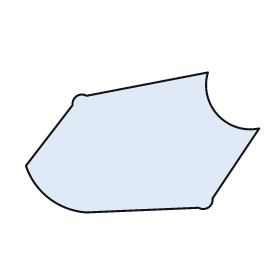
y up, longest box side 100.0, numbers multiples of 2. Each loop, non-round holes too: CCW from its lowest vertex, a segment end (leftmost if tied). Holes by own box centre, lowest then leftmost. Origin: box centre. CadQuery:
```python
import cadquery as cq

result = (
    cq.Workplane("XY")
    .moveTo(-24.0, -30.0)
    .lineTo(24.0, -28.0)
    .threePointArc((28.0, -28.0), (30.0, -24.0))
    .lineTo(50.0, 6.0)
    .threePointArc((32.0, 12.0), (28.0, 30.0))
    .lineTo(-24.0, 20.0)
    .threePointArc((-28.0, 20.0), (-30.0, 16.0))
    .lineTo(-50.0, -10.0)
    .threePointArc((-40.0, -24.0), (-24.0, -30.0))
    .close()
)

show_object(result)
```